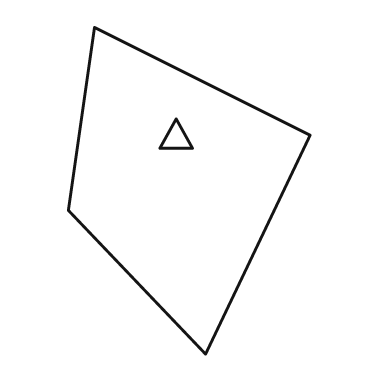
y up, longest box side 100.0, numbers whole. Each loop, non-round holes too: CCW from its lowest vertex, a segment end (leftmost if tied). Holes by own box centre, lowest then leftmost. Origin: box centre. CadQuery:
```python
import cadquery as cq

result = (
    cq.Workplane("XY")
    .moveTo(5.0, -50.0)
    .lineTo(37.0, 17.0)
    .lineTo(-29.0, 50.0)
    .lineTo(-37.0, -6.0)
    .close()
    .moveTo(-9.0, 13.0)
    .lineTo(1.0, 13.0)
    .lineTo(-4.0, 22.0)
    .close()
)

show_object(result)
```